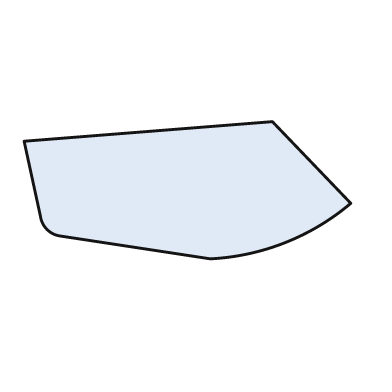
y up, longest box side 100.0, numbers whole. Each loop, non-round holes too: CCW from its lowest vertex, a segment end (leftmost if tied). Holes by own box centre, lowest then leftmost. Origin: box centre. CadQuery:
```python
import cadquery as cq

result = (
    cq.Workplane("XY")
    .moveTo(7.0, -21.0)
    .threePointArc((30.0, -16.0), (50.0, -4.0))
    .lineTo(26.0, 21.0)
    .lineTo(-50.0, 15.0)
    .lineTo(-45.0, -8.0)
    .threePointArc((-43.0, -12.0), (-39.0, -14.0))
    .close()
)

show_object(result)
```